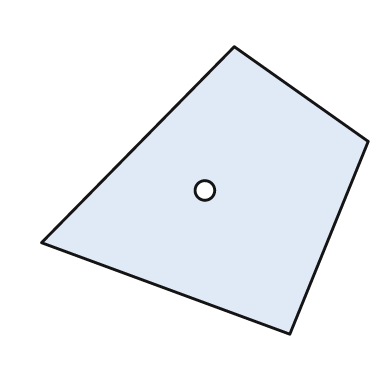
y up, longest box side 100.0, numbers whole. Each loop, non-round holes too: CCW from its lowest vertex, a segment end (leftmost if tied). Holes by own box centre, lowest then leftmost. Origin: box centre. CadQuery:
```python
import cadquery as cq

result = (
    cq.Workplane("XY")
    .moveTo(26.0, -44.0)
    .lineTo(50.0, 15.0)
    .lineTo(9.0, 44.0)
    .lineTo(-50.0, -16.0)
    .close()
    .moveTo(0.0, 0.0)
    .circle(3.0)
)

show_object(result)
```